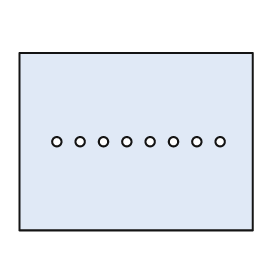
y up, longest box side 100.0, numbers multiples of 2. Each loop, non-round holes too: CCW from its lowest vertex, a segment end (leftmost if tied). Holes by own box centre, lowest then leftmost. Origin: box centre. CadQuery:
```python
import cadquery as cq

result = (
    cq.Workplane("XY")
    .moveTo(-50.0, -38.0)
    .lineTo(50.0, -38.0)
    .lineTo(50.0, 38.0)
    .lineTo(-50.0, 38.0)
    .close()
    .moveTo(-34.0, 0.0)
    .circle(2.0)
    .moveTo(-24.0, 0.0)
    .circle(2.0)
    .moveTo(-14.0, 0.0)
    .circle(2.0)
    .moveTo(-4.0, 0.0)
    .circle(2.0)
    .moveTo(6.0, 0.0)
    .circle(2.0)
    .moveTo(16.0, 0.0)
    .circle(2.0)
    .moveTo(26.0, 0.0)
    .circle(2.0)
    .moveTo(36.0, 0.0)
    .circle(2.0)
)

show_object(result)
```